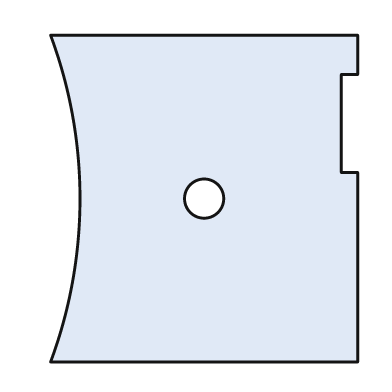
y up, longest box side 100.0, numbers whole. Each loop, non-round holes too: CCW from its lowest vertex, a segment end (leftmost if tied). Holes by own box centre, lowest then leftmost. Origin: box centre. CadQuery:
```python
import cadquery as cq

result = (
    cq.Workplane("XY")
    .moveTo(-47.0, -50.0)
    .lineTo(47.0, -50.0)
    .lineTo(47.0, 8.0)
    .lineTo(42.0, 8.0)
    .lineTo(42.0, 38.0)
    .lineTo(47.0, 38.0)
    .lineTo(47.0, 50.0)
    .lineTo(-47.0, 50.0)
    .threePointArc((-38.0, 0.0), (-47.0, -50.0))
    .close()
    .moveTo(0.0, 0.0)
    .circle(6.0)
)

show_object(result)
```